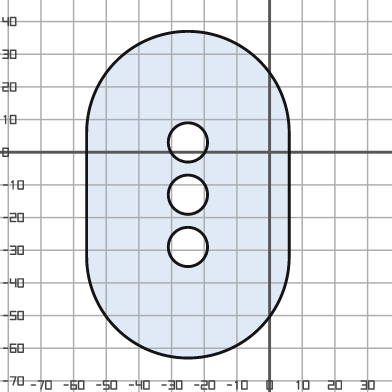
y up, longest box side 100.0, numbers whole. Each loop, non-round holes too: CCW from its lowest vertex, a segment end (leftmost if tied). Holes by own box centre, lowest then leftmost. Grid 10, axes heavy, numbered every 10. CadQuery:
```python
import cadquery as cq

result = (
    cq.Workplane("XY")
    .moveTo(-56.0, -32.0)
    .threePointArc((-25.0, -63.0), (6.0, -32.0))
    .lineTo(6.0, 6.0)
    .threePointArc((-25.0, 37.0), (-56.0, 6.0))
    .close()
    .moveTo(-25.0, -29.0)
    .circle(6.0)
    .moveTo(-25.0, -13.0)
    .circle(6.0)
    .moveTo(-25.0, 3.0)
    .circle(6.0)
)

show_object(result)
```